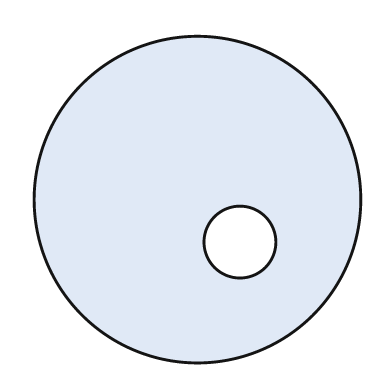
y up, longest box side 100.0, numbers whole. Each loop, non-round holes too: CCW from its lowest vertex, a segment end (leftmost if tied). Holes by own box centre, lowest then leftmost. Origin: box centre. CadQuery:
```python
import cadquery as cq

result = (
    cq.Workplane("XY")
    .moveTo(0.0, 0.0)
    .circle(50.0)
    .moveTo(13.0, -13.0)
    .circle(11.0)
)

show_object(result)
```